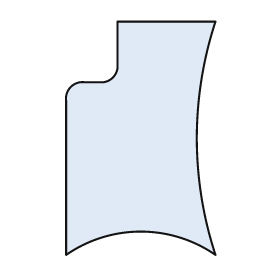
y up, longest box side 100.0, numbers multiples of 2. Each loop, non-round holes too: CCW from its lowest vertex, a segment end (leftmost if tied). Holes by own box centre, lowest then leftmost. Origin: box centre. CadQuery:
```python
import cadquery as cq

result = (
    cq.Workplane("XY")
    .moveTo(-32.0, -50.0)
    .threePointArc((0.0, -40.0), (32.0, -50.0))
    .threePointArc((24.0, 0.0), (32.0, 50.0))
    .lineTo(-10.0, 50.0)
    .lineTo(-10.0, 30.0)
    .threePointArc((-12.0, 26.0), (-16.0, 24.0))
    .lineTo(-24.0, 24.0)
    .threePointArc((-30.0, 22.0), (-32.0, 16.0))
    .close()
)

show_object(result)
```